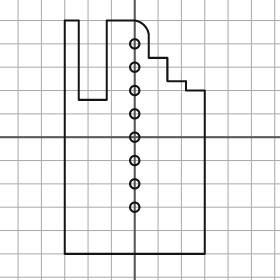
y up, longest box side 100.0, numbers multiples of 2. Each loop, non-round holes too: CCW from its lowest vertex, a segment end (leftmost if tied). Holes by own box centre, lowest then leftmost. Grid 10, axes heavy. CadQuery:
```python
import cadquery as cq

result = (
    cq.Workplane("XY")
    .moveTo(-30.0, -50.0)
    .lineTo(30.0, -50.0)
    .lineTo(30.0, 20.0)
    .lineTo(22.0, 20.0)
    .lineTo(22.0, 24.0)
    .lineTo(14.0, 24.0)
    .lineTo(14.0, 34.0)
    .lineTo(6.0, 34.0)
    .lineTo(6.0, 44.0)
    .threePointArc((4.0, 48.0), (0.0, 50.0))
    .lineTo(-12.0, 50.0)
    .lineTo(-12.0, 16.0)
    .lineTo(-24.0, 16.0)
    .lineTo(-24.0, 50.0)
    .lineTo(-30.0, 50.0)
    .close()
    .moveTo(0.0, -30.0)
    .circle(2.0)
    .moveTo(0.0, -20.0)
    .circle(2.0)
    .moveTo(0.0, -10.0)
    .circle(2.0)
    .moveTo(0.0, 0.0)
    .circle(2.0)
    .moveTo(0.0, 10.0)
    .circle(2.0)
    .moveTo(0.0, 20.0)
    .circle(2.0)
    .moveTo(0.0, 30.0)
    .circle(2.0)
    .moveTo(0.0, 40.0)
    .circle(2.0)
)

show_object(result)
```